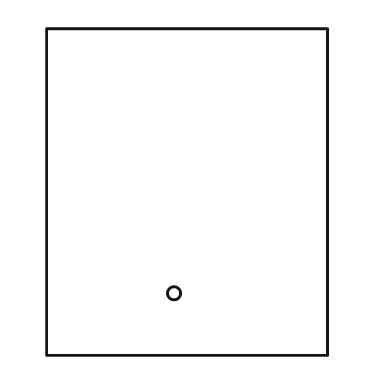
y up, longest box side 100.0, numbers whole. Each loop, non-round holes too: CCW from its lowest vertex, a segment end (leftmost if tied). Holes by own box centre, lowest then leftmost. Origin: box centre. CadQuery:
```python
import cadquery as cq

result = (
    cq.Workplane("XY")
    .moveTo(-43.0, -50.0)
    .lineTo(43.0, -50.0)
    .lineTo(43.0, 50.0)
    .lineTo(-43.0, 50.0)
    .close()
    .moveTo(-4.0, -31.0)
    .circle(2.0)
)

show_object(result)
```